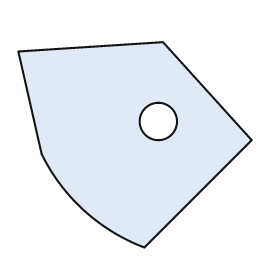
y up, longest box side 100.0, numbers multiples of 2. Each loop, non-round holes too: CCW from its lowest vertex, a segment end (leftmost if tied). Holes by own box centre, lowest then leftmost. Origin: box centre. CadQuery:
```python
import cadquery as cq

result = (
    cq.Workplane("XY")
    .moveTo(4.0, -44.0)
    .lineTo(50.0, 2.0)
    .lineTo(12.0, 44.0)
    .lineTo(-50.0, 40.0)
    .lineTo(-40.0, -4.0)
    .threePointArc((-22.0, -28.0), (4.0, -44.0))
    .close()
    .moveTo(10.0, 10.0)
    .circle(8.0)
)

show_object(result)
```